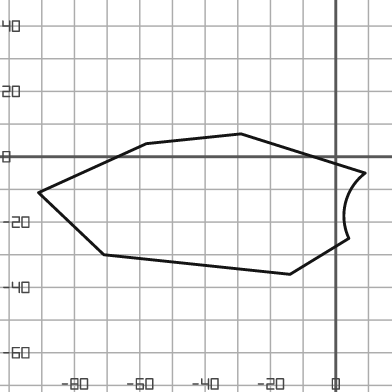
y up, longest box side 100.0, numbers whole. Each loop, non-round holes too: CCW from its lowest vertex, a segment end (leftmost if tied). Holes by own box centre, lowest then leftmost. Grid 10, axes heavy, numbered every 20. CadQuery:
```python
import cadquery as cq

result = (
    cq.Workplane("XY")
    .moveTo(-14.0, -36.0)
    .lineTo(4.0, -25.0)
    .threePointArc((3.0, -14.0), (9.0, -5.0))
    .lineTo(-29.0, 7.0)
    .lineTo(-58.0, 4.0)
    .lineTo(-91.0, -11.0)
    .lineTo(-71.0, -30.0)
    .close()
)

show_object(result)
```